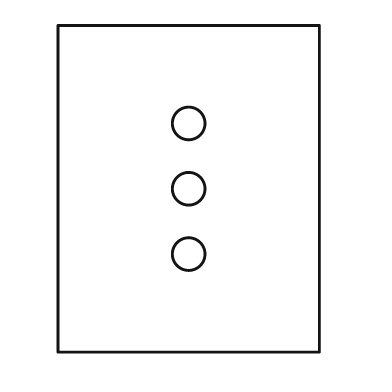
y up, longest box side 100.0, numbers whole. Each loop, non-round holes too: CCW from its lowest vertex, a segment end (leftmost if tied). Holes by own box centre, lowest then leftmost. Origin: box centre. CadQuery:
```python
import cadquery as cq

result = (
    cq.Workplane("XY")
    .moveTo(-40.0, -50.0)
    .lineTo(40.0, -50.0)
    .lineTo(40.0, 50.0)
    .lineTo(-40.0, 50.0)
    .close()
    .moveTo(0.0, -20.0)
    .circle(5.0)
    .moveTo(0.0, 0.0)
    .circle(5.0)
    .moveTo(0.0, 20.0)
    .circle(5.0)
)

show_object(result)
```